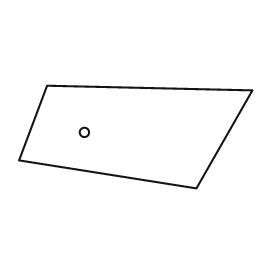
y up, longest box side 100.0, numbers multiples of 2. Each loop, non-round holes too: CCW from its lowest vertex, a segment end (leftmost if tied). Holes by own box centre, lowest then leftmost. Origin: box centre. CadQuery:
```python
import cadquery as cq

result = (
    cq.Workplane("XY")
    .moveTo(26.0, -22.0)
    .lineTo(50.0, 20.0)
    .lineTo(-38.0, 22.0)
    .lineTo(-50.0, -10.0)
    .close()
    .moveTo(-22.0, 2.0)
    .circle(2.0)
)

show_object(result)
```